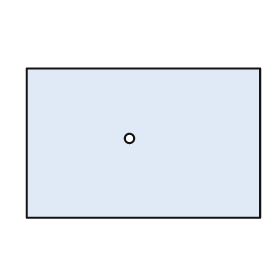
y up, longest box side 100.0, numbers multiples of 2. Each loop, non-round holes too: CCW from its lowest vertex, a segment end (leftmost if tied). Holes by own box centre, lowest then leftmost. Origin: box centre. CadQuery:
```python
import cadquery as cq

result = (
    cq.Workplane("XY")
    .moveTo(-50.0, -32.0)
    .lineTo(50.0, -32.0)
    .lineTo(50.0, 32.0)
    .lineTo(-50.0, 32.0)
    .close()
    .moveTo(-6.0, 2.0)
    .circle(2.0)
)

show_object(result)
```